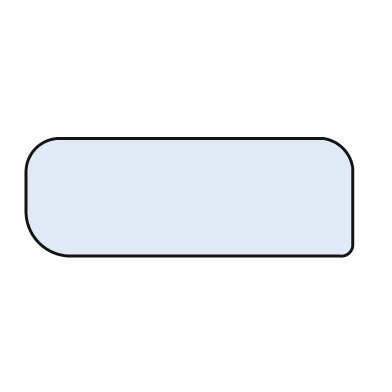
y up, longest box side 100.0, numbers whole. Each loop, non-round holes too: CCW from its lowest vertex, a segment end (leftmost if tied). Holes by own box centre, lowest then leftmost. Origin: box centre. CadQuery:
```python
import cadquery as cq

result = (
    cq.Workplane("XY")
    .moveTo(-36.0, -18.0)
    .lineTo(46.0, -18.0)
    .threePointArc((49.0, -17.0), (50.0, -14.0))
    .lineTo(50.0, 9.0)
    .threePointArc((47.0, 15.0), (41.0, 18.0))
    .lineTo(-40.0, 18.0)
    .threePointArc((-47.0, 15.0), (-50.0, 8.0))
    .lineTo(-50.0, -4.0)
    .threePointArc((-46.0, -14.0), (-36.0, -18.0))
    .close()
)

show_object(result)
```